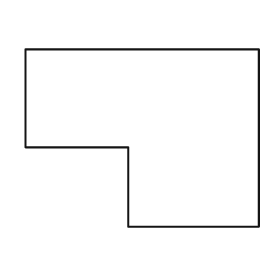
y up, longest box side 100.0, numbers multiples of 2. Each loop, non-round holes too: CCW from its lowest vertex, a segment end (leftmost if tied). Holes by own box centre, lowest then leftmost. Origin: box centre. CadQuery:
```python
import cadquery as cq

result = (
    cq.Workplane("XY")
    .moveTo(-6.0, -38.0)
    .lineTo(50.0, -38.0)
    .lineTo(50.0, 38.0)
    .lineTo(-50.0, 38.0)
    .lineTo(-50.0, -4.0)
    .lineTo(-6.0, -4.0)
    .close()
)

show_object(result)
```